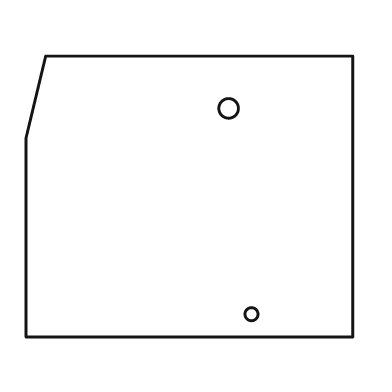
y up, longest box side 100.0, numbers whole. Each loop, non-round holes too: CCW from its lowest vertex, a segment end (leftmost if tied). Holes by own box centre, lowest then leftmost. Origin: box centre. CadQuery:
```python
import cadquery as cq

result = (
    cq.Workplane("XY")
    .moveTo(-50.0, -43.0)
    .lineTo(50.0, -43.0)
    .lineTo(50.0, 43.0)
    .lineTo(-44.0, 43.0)
    .lineTo(-50.0, 18.0)
    .close()
    .moveTo(19.0, -36.0)
    .circle(2.0)
    .moveTo(12.0, 27.0)
    .circle(3.0)
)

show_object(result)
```